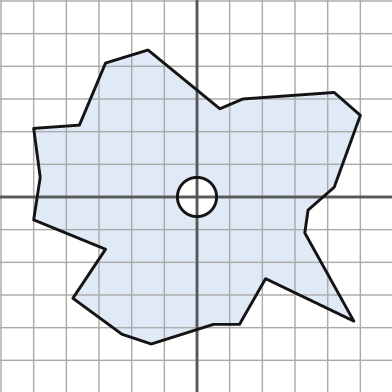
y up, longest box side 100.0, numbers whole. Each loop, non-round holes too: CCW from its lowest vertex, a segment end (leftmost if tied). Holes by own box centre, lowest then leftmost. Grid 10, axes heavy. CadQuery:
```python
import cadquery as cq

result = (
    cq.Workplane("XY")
    .moveTo(-14.0, -45.0)
    .lineTo(5.0, -39.0)
    .lineTo(13.0, -39.0)
    .lineTo(21.0, -25.0)
    .lineTo(48.0, -38.0)
    .lineTo(33.0, -11.0)
    .lineTo(34.0, -4.0)
    .lineTo(42.0, 3.0)
    .lineTo(50.0, 25.0)
    .lineTo(42.0, 32.0)
    .lineTo(14.0, 30.0)
    .lineTo(7.0, 27.0)
    .lineTo(-15.0, 45.0)
    .lineTo(-28.0, 41.0)
    .lineTo(-36.0, 22.0)
    .lineTo(-50.0, 21.0)
    .lineTo(-48.0, 6.0)
    .lineTo(-50.0, -7.0)
    .lineTo(-28.0, -16.0)
    .lineTo(-38.0, -31.0)
    .lineTo(-23.0, -42.0)
    .close()
    .moveTo(0.0, 0.0)
    .circle(6.0)
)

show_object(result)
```